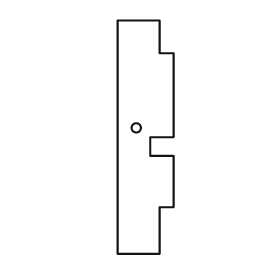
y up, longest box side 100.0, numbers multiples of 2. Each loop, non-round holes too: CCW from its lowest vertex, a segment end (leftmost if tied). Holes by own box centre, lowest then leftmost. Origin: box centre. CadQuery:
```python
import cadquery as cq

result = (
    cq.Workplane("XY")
    .moveTo(-12.0, -50.0)
    .lineTo(6.0, -50.0)
    .lineTo(6.0, -30.0)
    .lineTo(12.0, -30.0)
    .lineTo(12.0, -8.0)
    .lineTo(2.0, -8.0)
    .lineTo(2.0, 0.0)
    .lineTo(12.0, 0.0)
    .lineTo(12.0, 36.0)
    .lineTo(6.0, 36.0)
    .lineTo(6.0, 50.0)
    .lineTo(-12.0, 50.0)
    .close()
    .moveTo(-4.0, 4.0)
    .circle(2.0)
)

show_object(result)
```